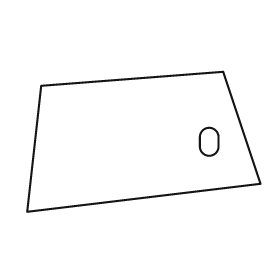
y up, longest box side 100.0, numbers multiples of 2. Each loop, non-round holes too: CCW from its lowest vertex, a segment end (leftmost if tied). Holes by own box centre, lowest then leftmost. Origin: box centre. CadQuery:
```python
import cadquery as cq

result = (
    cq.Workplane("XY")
    .moveTo(-50.0, -30.0)
    .lineTo(50.0, -18.0)
    .lineTo(34.0, 30.0)
    .lineTo(-44.0, 24.0)
    .close()
    .moveTo(24.0, -2.0)
    .threePointArc((28.0, -6.0), (32.0, -2.0))
    .lineTo(32.0, 2.0)
    .threePointArc((28.0, 6.0), (24.0, 2.0))
    .close()
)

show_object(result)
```